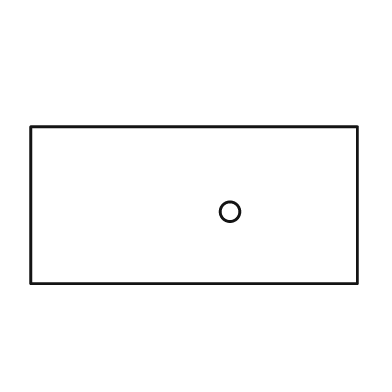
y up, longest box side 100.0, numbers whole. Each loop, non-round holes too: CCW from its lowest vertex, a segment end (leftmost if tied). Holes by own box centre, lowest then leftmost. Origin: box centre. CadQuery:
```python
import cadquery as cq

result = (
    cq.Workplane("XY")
    .moveTo(-50.0, -24.0)
    .lineTo(50.0, -24.0)
    .lineTo(50.0, 24.0)
    .lineTo(-50.0, 24.0)
    .close()
    .moveTo(11.0, -2.0)
    .circle(3.0)
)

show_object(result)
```